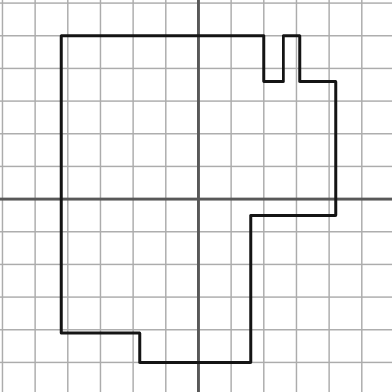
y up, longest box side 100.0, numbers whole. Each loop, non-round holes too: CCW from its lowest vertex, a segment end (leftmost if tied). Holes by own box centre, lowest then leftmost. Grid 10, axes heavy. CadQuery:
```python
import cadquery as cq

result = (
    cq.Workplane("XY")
    .moveTo(-18.0, -50.0)
    .lineTo(16.0, -50.0)
    .lineTo(16.0, -5.0)
    .lineTo(42.0, -5.0)
    .lineTo(42.0, 36.0)
    .lineTo(31.0, 36.0)
    .lineTo(31.0, 50.0)
    .lineTo(26.0, 50.0)
    .lineTo(26.0, 36.0)
    .lineTo(20.0, 36.0)
    .lineTo(20.0, 50.0)
    .lineTo(-42.0, 50.0)
    .lineTo(-42.0, -41.0)
    .lineTo(-18.0, -41.0)
    .close()
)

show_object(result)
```